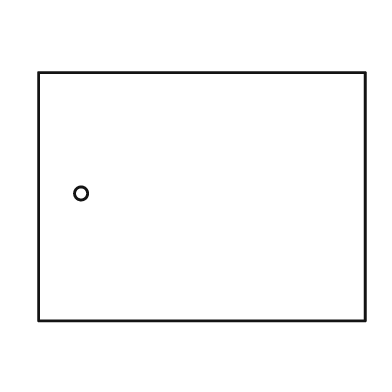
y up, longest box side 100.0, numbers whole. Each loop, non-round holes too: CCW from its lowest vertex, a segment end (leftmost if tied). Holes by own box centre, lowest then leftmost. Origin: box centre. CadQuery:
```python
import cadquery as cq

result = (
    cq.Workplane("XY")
    .moveTo(-50.0, -38.0)
    .lineTo(50.0, -38.0)
    .lineTo(50.0, 38.0)
    .lineTo(-50.0, 38.0)
    .close()
    .moveTo(-37.0, 1.0)
    .circle(2.0)
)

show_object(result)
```